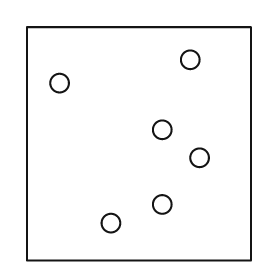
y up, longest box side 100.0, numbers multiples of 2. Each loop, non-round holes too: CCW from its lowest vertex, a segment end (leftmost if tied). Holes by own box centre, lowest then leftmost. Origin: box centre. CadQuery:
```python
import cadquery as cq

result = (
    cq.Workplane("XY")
    .moveTo(-48.0, -50.0)
    .lineTo(48.0, -50.0)
    .lineTo(48.0, 50.0)
    .lineTo(-48.0, 50.0)
    .close()
    .moveTo(-12.0, -34.0)
    .circle(4.0)
    .moveTo(10.0, -26.0)
    .circle(4.0)
    .moveTo(26.0, -6.0)
    .circle(4.0)
    .moveTo(10.0, 6.0)
    .circle(4.0)
    .moveTo(-34.0, 26.0)
    .circle(4.0)
    .moveTo(22.0, 36.0)
    .circle(4.0)
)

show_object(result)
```